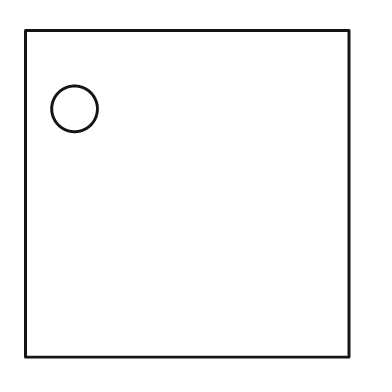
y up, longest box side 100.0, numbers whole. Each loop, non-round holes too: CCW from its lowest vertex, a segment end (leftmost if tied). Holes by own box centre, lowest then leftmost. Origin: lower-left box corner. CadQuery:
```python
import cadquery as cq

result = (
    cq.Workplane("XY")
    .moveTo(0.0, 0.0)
    .lineTo(99.0, 0.0)
    .lineTo(99.0, 100.0)
    .lineTo(0.0, 100.0)
    .close()
    .moveTo(15.0, 76.0)
    .circle(7.0)
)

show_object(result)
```